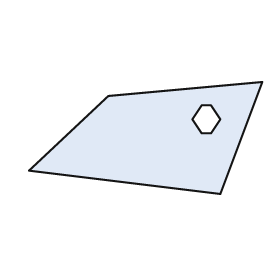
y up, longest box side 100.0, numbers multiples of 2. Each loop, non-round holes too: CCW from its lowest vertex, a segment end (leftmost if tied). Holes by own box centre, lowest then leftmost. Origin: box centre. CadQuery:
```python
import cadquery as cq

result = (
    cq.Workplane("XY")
    .moveTo(32.0, -24.0)
    .lineTo(50.0, 24.0)
    .lineTo(-16.0, 18.0)
    .lineTo(-50.0, -14.0)
    .close()
    .moveTo(24.0, 2.0)
    .lineTo(28.0, 2.0)
    .lineTo(32.0, 8.0)
    .lineTo(28.0, 14.0)
    .lineTo(24.0, 14.0)
    .lineTo(20.0, 8.0)
    .close()
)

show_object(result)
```